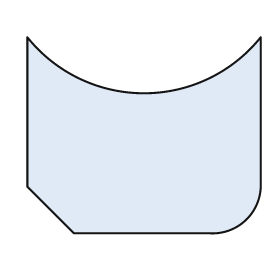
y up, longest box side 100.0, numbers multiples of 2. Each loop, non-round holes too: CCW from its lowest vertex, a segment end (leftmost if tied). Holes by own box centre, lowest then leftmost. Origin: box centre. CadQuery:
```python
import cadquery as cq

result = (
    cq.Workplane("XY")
    .moveTo(-30.0, -42.0)
    .lineTo(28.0, -42.0)
    .threePointArc((44.0, -36.0), (50.0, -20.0))
    .lineTo(50.0, 42.0)
    .threePointArc((0.0, 18.0), (-50.0, 42.0))
    .lineTo(-50.0, -22.0)
    .close()
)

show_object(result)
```